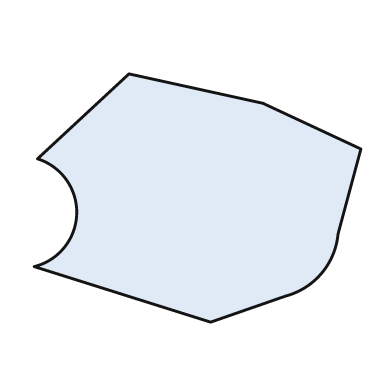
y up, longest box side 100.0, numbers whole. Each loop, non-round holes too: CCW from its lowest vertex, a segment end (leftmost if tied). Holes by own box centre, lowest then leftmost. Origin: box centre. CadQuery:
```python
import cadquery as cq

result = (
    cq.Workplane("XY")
    .moveTo(4.0, -38.0)
    .lineTo(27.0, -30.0)
    .threePointArc((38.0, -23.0), (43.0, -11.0))
    .lineTo(50.0, 15.0)
    .lineTo(20.0, 29.0)
    .lineTo(-21.0, 38.0)
    .lineTo(-49.0, 12.0)
    .threePointArc((-37.0, -5.0), (-50.0, -21.0))
    .close()
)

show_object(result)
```